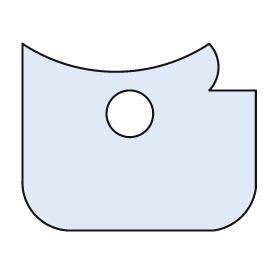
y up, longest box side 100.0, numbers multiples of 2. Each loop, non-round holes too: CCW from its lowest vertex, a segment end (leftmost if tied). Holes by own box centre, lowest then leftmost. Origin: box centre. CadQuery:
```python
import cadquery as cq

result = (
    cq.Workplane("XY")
    .moveTo(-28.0, -40.0)
    .lineTo(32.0, -40.0)
    .threePointArc((44.0, -34.0), (50.0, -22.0))
    .lineTo(50.0, 20.0)
    .lineTo(30.0, 20.0)
    .threePointArc((34.0, 30.0), (30.0, 40.0))
    .threePointArc((-10.0, 28.0), (-50.0, 40.0))
    .lineTo(-50.0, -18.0)
    .threePointArc((-44.0, -34.0), (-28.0, -40.0))
    .close()
    .moveTo(-4.0, 10.0)
    .circle(10.0)
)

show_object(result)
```